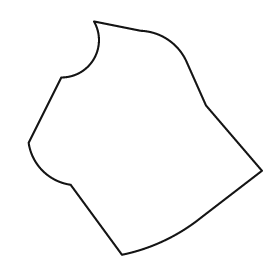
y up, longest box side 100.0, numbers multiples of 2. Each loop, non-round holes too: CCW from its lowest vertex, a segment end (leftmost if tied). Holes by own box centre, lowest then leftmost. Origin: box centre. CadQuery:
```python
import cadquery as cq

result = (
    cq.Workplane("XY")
    .moveTo(-10.0, -50.0)
    .threePointArc((8.0, -44.0), (24.0, -34.0))
    .lineTo(50.0, -14.0)
    .lineTo(26.0, 14.0)
    .lineTo(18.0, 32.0)
    .threePointArc((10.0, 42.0), (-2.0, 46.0))
    .lineTo(-22.0, 50.0)
    .threePointArc((-22.0, 34.0), (-36.0, 26.0))
    .lineTo(-50.0, -2.0)
    .threePointArc((-44.0, -14.0), (-32.0, -20.0))
    .close()
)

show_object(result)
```